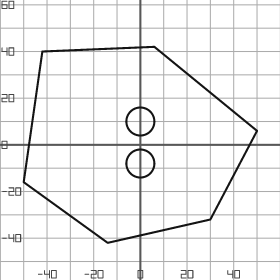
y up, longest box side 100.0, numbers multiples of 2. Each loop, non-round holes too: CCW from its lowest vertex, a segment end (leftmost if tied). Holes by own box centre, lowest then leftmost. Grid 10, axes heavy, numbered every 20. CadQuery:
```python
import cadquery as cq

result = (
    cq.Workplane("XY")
    .moveTo(-14.0, -42.0)
    .lineTo(30.0, -32.0)
    .lineTo(50.0, 6.0)
    .lineTo(6.0, 42.0)
    .lineTo(-42.0, 40.0)
    .lineTo(-50.0, -16.0)
    .close()
    .moveTo(0.0, -8.0)
    .circle(6.0)
    .moveTo(0.0, 10.0)
    .circle(6.0)
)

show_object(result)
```